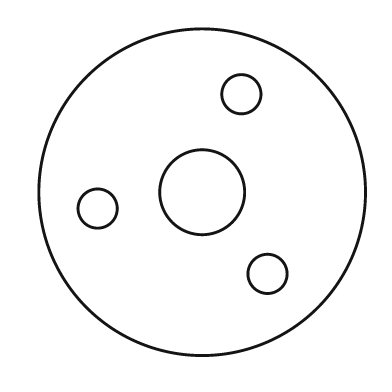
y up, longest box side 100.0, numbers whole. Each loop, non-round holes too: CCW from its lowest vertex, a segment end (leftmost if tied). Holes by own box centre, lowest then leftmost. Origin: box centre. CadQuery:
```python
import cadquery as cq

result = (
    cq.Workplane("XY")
    .moveTo(0.0, 0.0)
    .circle(50.0)
    .moveTo(20.0, -25.0)
    .circle(6.0)
    .moveTo(-32.0, -5.0)
    .circle(6.0)
    .moveTo(0.0, 0.0)
    .circle(13.0)
    .moveTo(12.0, 30.0)
    .circle(6.0)
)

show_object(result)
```